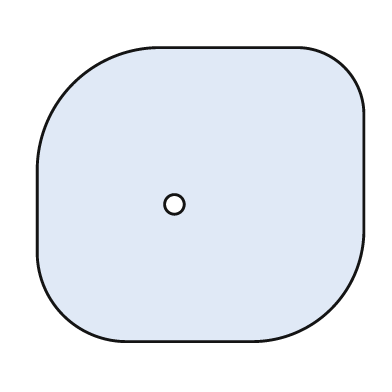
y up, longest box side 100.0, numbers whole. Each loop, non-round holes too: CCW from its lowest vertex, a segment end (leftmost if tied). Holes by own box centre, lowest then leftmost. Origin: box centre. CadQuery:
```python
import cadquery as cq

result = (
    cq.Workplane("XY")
    .moveTo(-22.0, -45.0)
    .lineTo(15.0, -45.0)
    .threePointArc((40.0, -35.0), (50.0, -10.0))
    .lineTo(50.0, 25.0)
    .threePointArc((44.0, 39.0), (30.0, 45.0))
    .lineTo(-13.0, 45.0)
    .threePointArc((-39.0, 34.0), (-50.0, 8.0))
    .lineTo(-50.0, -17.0)
    .threePointArc((-42.0, -37.0), (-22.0, -45.0))
    .close()
    .moveTo(-8.0, -3.0)
    .circle(3.0)
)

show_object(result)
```